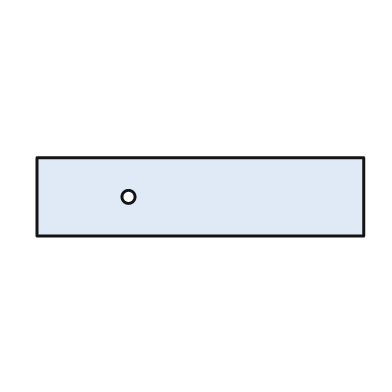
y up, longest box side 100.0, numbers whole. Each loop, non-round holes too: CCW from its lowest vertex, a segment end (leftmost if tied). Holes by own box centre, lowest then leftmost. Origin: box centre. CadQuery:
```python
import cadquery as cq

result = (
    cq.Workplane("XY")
    .moveTo(-50.0, -12.0)
    .lineTo(50.0, -12.0)
    .lineTo(50.0, 12.0)
    .lineTo(-50.0, 12.0)
    .close()
    .moveTo(-22.0, 0.0)
    .circle(2.0)
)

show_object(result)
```